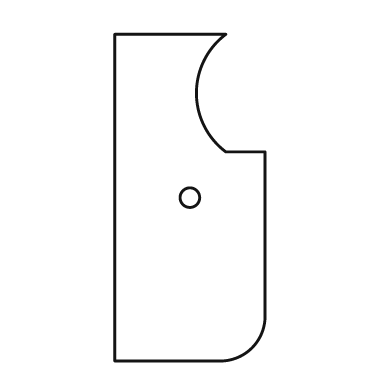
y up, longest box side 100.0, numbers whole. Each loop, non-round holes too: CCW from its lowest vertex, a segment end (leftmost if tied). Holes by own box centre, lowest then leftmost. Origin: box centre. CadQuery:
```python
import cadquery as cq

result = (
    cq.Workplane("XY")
    .moveTo(-23.0, -50.0)
    .lineTo(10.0, -50.0)
    .threePointArc((19.0, -46.0), (23.0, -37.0))
    .lineTo(23.0, 14.0)
    .lineTo(11.0, 14.0)
    .threePointArc((2.0, 32.0), (11.0, 50.0))
    .lineTo(-23.0, 50.0)
    .close()
    .moveTo(0.0, 0.0)
    .circle(3.0)
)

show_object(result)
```